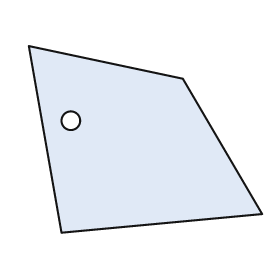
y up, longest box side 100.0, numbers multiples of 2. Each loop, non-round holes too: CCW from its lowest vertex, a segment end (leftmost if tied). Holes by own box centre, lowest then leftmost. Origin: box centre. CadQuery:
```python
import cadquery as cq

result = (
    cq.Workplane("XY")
    .moveTo(-36.0, -40.0)
    .lineTo(50.0, -32.0)
    .lineTo(16.0, 26.0)
    .lineTo(-50.0, 40.0)
    .close()
    .moveTo(-32.0, 8.0)
    .circle(4.0)
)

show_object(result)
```